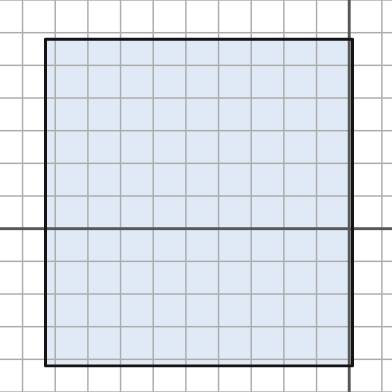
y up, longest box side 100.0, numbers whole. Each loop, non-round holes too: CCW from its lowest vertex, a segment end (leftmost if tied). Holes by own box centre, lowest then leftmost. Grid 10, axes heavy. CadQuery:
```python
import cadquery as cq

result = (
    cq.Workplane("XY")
    .moveTo(-93.0, -42.0)
    .lineTo(1.0, -42.0)
    .lineTo(1.0, 58.0)
    .lineTo(-93.0, 58.0)
    .close()
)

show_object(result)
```